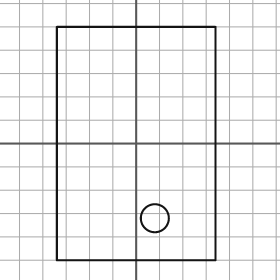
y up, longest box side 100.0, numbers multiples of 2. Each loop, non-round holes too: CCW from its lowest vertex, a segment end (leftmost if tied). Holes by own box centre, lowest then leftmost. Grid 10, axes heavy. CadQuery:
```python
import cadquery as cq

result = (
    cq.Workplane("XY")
    .moveTo(-34.0, -50.0)
    .lineTo(34.0, -50.0)
    .lineTo(34.0, 50.0)
    .lineTo(-34.0, 50.0)
    .close()
    .moveTo(8.0, -32.0)
    .circle(6.0)
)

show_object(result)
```